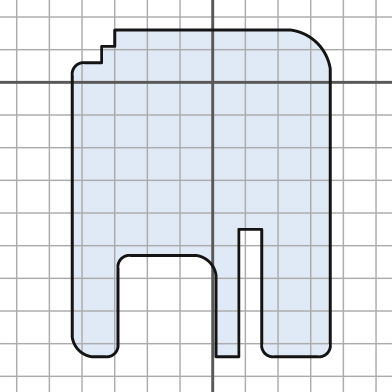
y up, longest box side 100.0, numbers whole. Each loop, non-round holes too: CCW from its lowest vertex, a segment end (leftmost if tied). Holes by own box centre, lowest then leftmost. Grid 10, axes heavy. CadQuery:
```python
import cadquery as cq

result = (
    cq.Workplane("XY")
    .moveTo(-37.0, -84.0)
    .lineTo(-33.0, -84.0)
    .threePointArc((-30.0, -83.0), (-29.0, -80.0))
    .lineTo(-29.0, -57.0)
    .threePointArc((-28.0, -54.0), (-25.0, -53.0))
    .lineTo(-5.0, -53.0)
    .threePointArc((-1.0, -55.0), (1.0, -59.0))
    .lineTo(1.0, -84.0)
    .lineTo(8.0, -84.0)
    .lineTo(8.0, -45.0)
    .lineTo(15.0, -45.0)
    .lineTo(15.0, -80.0)
    .threePointArc((16.0, -83.0), (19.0, -84.0))
    .lineTo(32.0, -84.0)
    .threePointArc((35.0, -83.0), (36.0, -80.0))
    .lineTo(36.0, 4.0)
    .threePointArc((32.0, 12.0), (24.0, 16.0))
    .lineTo(-30.0, 16.0)
    .lineTo(-30.0, 11.0)
    .lineTo(-34.0, 11.0)
    .lineTo(-34.0, 6.0)
    .lineTo(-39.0, 6.0)
    .threePointArc((-42.0, 5.0), (-43.0, 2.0))
    .lineTo(-43.0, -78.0)
    .threePointArc((-41.0, -82.0), (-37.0, -84.0))
    .close()
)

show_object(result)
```